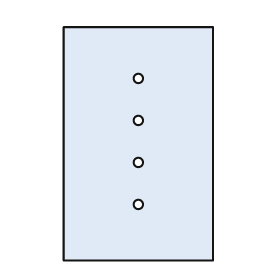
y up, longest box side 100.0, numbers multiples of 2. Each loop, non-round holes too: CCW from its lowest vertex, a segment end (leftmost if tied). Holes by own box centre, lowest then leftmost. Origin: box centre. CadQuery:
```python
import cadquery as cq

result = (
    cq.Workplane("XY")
    .moveTo(-32.0, -50.0)
    .lineTo(32.0, -50.0)
    .lineTo(32.0, 50.0)
    .lineTo(-32.0, 50.0)
    .close()
    .moveTo(0.0, -26.0)
    .circle(2.0)
    .moveTo(0.0, -8.0)
    .circle(2.0)
    .moveTo(0.0, 10.0)
    .circle(2.0)
    .moveTo(0.0, 28.0)
    .circle(2.0)
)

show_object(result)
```